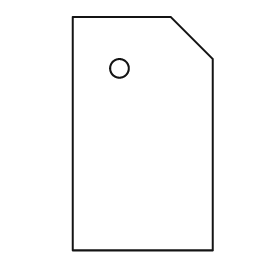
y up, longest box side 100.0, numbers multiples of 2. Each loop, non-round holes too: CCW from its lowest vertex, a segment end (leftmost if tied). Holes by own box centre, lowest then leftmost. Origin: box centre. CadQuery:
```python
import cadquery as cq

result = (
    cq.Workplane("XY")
    .moveTo(-30.0, -50.0)
    .lineTo(30.0, -50.0)
    .lineTo(30.0, 32.0)
    .lineTo(12.0, 50.0)
    .lineTo(-30.0, 50.0)
    .close()
    .moveTo(-10.0, 28.0)
    .circle(4.0)
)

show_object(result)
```